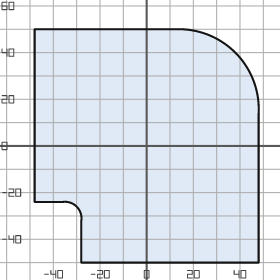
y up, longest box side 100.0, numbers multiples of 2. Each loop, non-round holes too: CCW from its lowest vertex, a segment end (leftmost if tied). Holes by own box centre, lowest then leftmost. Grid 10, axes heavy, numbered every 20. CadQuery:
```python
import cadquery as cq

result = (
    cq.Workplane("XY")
    .moveTo(-28.0, -50.0)
    .lineTo(48.0, -50.0)
    .lineTo(48.0, 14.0)
    .threePointArc((38.0, 40.0), (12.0, 50.0))
    .lineTo(-48.0, 50.0)
    .lineTo(-48.0, -24.0)
    .lineTo(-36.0, -24.0)
    .threePointArc((-30.0, -26.0), (-28.0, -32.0))
    .close()
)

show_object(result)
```